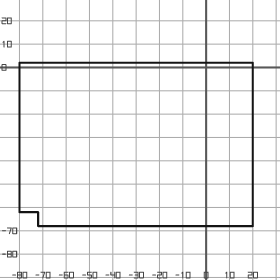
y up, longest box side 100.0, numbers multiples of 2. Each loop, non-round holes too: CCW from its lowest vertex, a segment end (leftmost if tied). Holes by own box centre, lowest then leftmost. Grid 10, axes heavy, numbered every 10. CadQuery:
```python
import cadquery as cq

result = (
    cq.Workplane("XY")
    .moveTo(-72.0, -68.0)
    .lineTo(20.0, -68.0)
    .lineTo(20.0, 2.0)
    .lineTo(-80.0, 2.0)
    .lineTo(-80.0, -62.0)
    .lineTo(-72.0, -62.0)
    .close()
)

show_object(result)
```